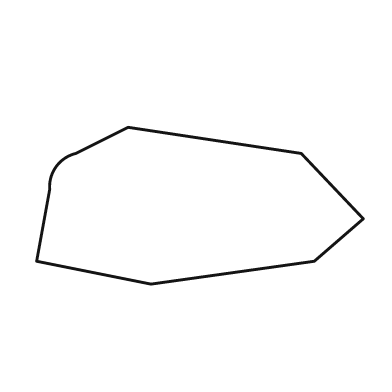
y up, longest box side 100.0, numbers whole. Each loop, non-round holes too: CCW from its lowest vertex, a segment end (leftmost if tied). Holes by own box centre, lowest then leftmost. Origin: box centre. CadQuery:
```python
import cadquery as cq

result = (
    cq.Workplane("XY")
    .moveTo(-15.0, -24.0)
    .lineTo(35.0, -17.0)
    .lineTo(50.0, -4.0)
    .lineTo(31.0, 16.0)
    .lineTo(-22.0, 24.0)
    .lineTo(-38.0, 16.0)
    .threePointArc((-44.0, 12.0), (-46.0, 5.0))
    .lineTo(-50.0, -17.0)
    .close()
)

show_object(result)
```